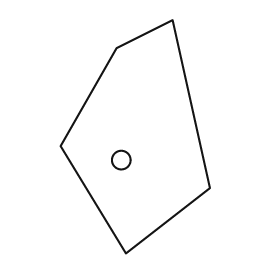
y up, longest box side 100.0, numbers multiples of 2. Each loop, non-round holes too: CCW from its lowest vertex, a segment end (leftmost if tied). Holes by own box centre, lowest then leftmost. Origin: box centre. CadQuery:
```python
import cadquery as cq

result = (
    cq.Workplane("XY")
    .moveTo(-4.0, -50.0)
    .lineTo(32.0, -22.0)
    .lineTo(16.0, 50.0)
    .lineTo(-8.0, 38.0)
    .lineTo(-32.0, -4.0)
    .close()
    .moveTo(-6.0, -10.0)
    .circle(4.0)
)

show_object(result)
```